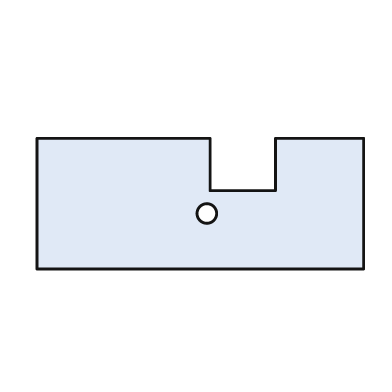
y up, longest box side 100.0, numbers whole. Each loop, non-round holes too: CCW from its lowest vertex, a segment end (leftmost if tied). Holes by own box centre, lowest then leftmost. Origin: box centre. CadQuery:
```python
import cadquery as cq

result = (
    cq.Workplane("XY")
    .moveTo(-50.0, -20.0)
    .lineTo(50.0, -20.0)
    .lineTo(50.0, 20.0)
    .lineTo(23.0, 20.0)
    .lineTo(23.0, 4.0)
    .lineTo(3.0, 4.0)
    .lineTo(3.0, 20.0)
    .lineTo(-50.0, 20.0)
    .close()
    .moveTo(2.0, -3.0)
    .circle(3.0)
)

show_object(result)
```